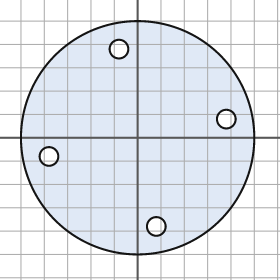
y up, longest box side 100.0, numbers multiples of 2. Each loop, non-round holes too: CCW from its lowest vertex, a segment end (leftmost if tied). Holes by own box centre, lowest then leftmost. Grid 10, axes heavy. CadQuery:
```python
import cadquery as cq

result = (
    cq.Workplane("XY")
    .moveTo(0.0, 0.0)
    .circle(50.0)
    .moveTo(8.0, -38.0)
    .circle(4.0)
    .moveTo(-38.0, -8.0)
    .circle(4.0)
    .moveTo(38.0, 8.0)
    .circle(4.0)
    .moveTo(-8.0, 38.0)
    .circle(4.0)
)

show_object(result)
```